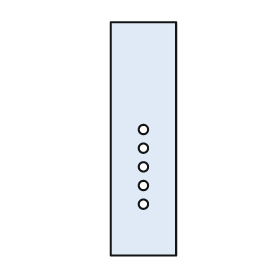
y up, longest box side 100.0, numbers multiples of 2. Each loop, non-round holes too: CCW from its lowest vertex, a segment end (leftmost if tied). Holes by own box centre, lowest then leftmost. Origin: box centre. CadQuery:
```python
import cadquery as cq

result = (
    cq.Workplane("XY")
    .moveTo(-14.0, -50.0)
    .lineTo(14.0, -50.0)
    .lineTo(14.0, 50.0)
    .lineTo(-14.0, 50.0)
    .close()
    .moveTo(0.0, -28.0)
    .circle(2.0)
    .moveTo(0.0, -20.0)
    .circle(2.0)
    .moveTo(0.0, -12.0)
    .circle(2.0)
    .moveTo(0.0, -4.0)
    .circle(2.0)
    .moveTo(0.0, 4.0)
    .circle(2.0)
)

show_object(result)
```